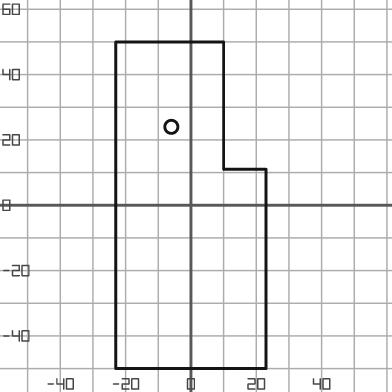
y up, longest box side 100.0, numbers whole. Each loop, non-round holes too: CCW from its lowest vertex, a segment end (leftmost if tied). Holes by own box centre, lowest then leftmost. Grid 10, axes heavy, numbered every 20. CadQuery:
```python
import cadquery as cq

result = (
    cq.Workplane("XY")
    .moveTo(-23.0, -50.0)
    .lineTo(23.0, -50.0)
    .lineTo(23.0, 11.0)
    .lineTo(10.0, 11.0)
    .lineTo(10.0, 50.0)
    .lineTo(-23.0, 50.0)
    .close()
    .moveTo(-6.0, 24.0)
    .circle(2.0)
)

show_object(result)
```